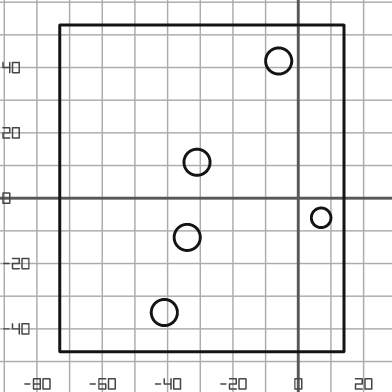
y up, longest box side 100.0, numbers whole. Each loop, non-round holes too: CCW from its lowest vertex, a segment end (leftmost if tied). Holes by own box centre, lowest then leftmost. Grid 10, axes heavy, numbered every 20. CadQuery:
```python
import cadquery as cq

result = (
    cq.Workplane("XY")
    .moveTo(-73.0, -47.0)
    .lineTo(14.0, -47.0)
    .lineTo(14.0, 53.0)
    .lineTo(-73.0, 53.0)
    .close()
    .moveTo(-41.0, -35.0)
    .circle(4.0)
    .moveTo(-34.0, -12.0)
    .circle(4.0)
    .moveTo(7.0, -6.0)
    .circle(3.0)
    .moveTo(-31.0, 11.0)
    .circle(4.0)
    .moveTo(-6.0, 42.0)
    .circle(4.0)
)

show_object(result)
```